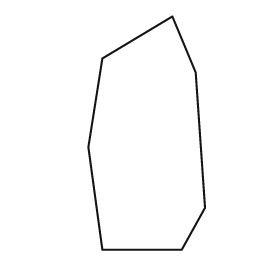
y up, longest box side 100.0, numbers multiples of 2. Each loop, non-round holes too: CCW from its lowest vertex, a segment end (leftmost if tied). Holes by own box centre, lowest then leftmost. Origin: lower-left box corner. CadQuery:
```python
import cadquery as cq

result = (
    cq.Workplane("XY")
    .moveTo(6.0, 0.0)
    .lineTo(40.0, 0.0)
    .lineTo(50.0, 18.0)
    .lineTo(46.0, 76.0)
    .lineTo(36.0, 100.0)
    .lineTo(6.0, 82.0)
    .lineTo(0.0, 44.0)
    .close()
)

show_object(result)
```